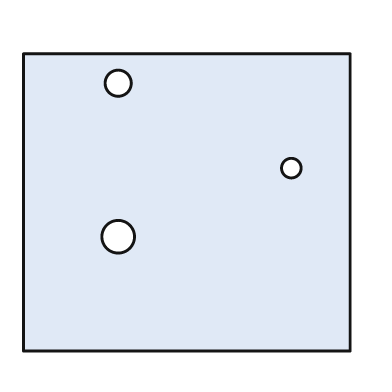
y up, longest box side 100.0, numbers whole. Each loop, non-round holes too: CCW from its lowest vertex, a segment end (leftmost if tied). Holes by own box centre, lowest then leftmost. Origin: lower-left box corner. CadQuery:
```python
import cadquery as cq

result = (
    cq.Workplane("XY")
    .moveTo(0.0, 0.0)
    .lineTo(100.0, 0.0)
    .lineTo(100.0, 91.0)
    .lineTo(0.0, 91.0)
    .close()
    .moveTo(29.0, 35.0)
    .circle(5.0)
    .moveTo(82.0, 56.0)
    .circle(3.0)
    .moveTo(29.0, 82.0)
    .circle(4.0)
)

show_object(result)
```